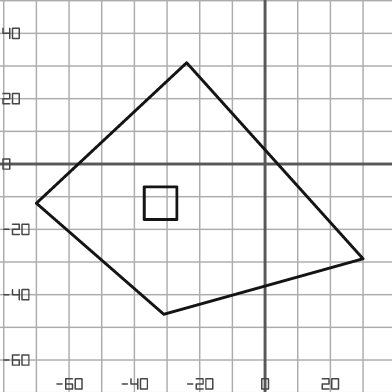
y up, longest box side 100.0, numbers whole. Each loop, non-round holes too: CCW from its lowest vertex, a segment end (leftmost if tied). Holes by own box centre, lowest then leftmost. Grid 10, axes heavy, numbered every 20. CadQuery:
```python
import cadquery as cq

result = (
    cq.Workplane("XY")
    .moveTo(-31.0, -46.0)
    .lineTo(30.0, -29.0)
    .lineTo(-24.0, 31.0)
    .lineTo(-70.0, -12.0)
    .close()
    .moveTo(-37.0, -17.0)
    .lineTo(-27.0, -17.0)
    .lineTo(-27.0, -7.0)
    .lineTo(-37.0, -7.0)
    .close()
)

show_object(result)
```